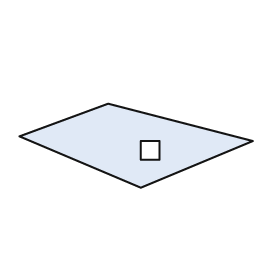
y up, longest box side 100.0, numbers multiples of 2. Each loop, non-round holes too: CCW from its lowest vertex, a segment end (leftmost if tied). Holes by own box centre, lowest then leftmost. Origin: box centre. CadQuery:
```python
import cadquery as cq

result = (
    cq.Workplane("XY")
    .moveTo(2.0, -18.0)
    .lineTo(50.0, 2.0)
    .lineTo(-12.0, 18.0)
    .lineTo(-50.0, 4.0)
    .close()
    .moveTo(2.0, -6.0)
    .lineTo(10.0, -6.0)
    .lineTo(10.0, 2.0)
    .lineTo(2.0, 2.0)
    .close()
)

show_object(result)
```